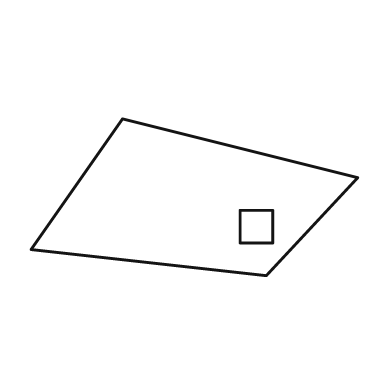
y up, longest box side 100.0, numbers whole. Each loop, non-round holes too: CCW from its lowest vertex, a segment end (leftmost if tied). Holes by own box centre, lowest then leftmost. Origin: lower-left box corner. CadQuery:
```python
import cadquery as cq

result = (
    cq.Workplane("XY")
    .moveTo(72.0, 0.0)
    .lineTo(100.0, 30.0)
    .lineTo(28.0, 48.0)
    .lineTo(0.0, 8.0)
    .close()
    .moveTo(64.0, 10.0)
    .lineTo(74.0, 10.0)
    .lineTo(74.0, 20.0)
    .lineTo(64.0, 20.0)
    .close()
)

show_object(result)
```